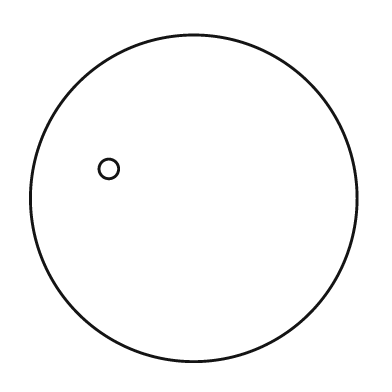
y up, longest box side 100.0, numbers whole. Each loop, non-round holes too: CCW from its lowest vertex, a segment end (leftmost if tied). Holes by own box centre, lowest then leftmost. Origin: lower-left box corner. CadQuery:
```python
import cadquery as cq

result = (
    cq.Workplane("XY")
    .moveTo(50.0, 50.0)
    .circle(50.0)
    .moveTo(24.0, 59.0)
    .circle(3.0)
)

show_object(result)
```